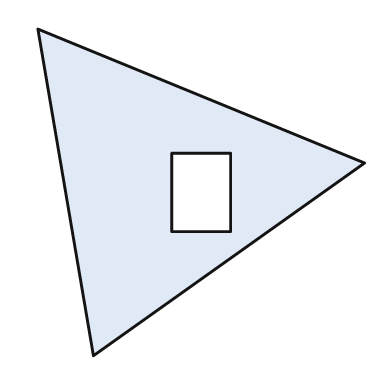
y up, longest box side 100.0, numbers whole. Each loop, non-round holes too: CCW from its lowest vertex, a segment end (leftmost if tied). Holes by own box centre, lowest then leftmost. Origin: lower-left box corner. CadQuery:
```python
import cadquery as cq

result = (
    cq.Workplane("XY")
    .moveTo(17.0, 0.0)
    .lineTo(100.0, 59.0)
    .lineTo(0.0, 100.0)
    .close()
    .moveTo(41.0, 38.0)
    .lineTo(59.0, 38.0)
    .lineTo(59.0, 62.0)
    .lineTo(41.0, 62.0)
    .close()
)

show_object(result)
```